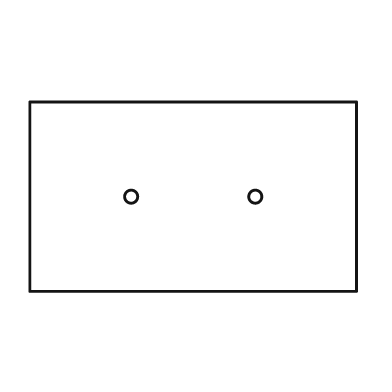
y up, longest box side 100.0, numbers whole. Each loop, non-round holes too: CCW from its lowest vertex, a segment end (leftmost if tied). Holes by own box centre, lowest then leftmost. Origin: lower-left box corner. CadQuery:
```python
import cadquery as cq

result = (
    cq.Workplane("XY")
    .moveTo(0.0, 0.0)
    .lineTo(100.0, 0.0)
    .lineTo(100.0, 58.0)
    .lineTo(0.0, 58.0)
    .close()
    .moveTo(31.0, 29.0)
    .circle(2.0)
    .moveTo(69.0, 29.0)
    .circle(2.0)
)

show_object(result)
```